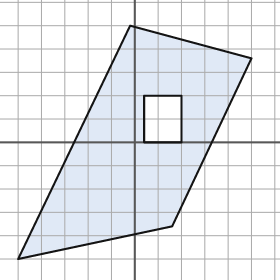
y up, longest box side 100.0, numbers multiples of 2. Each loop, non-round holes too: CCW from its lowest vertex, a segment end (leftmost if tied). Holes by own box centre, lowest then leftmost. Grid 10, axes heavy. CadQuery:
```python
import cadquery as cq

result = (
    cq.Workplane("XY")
    .moveTo(-50.0, -50.0)
    .lineTo(16.0, -36.0)
    .lineTo(50.0, 36.0)
    .lineTo(-2.0, 50.0)
    .close()
    .moveTo(4.0, 0.0)
    .lineTo(20.0, 0.0)
    .lineTo(20.0, 20.0)
    .lineTo(4.0, 20.0)
    .close()
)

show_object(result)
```